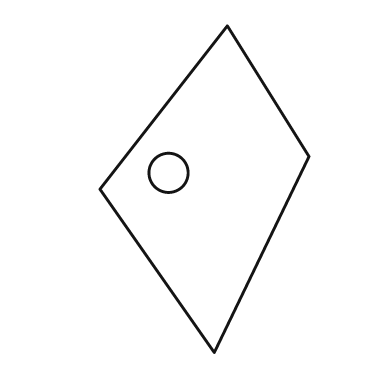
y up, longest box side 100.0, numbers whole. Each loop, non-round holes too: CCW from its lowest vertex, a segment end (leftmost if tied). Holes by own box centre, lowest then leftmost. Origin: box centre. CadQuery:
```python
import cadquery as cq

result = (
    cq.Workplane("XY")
    .moveTo(3.0, -50.0)
    .lineTo(32.0, 10.0)
    .lineTo(7.0, 50.0)
    .lineTo(-32.0, 0.0)
    .close()
    .moveTo(-11.0, 5.0)
    .circle(6.0)
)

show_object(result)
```